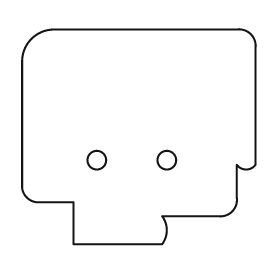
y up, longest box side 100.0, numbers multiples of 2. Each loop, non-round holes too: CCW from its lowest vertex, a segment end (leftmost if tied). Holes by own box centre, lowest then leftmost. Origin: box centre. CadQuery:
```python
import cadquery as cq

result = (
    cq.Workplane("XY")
    .moveTo(-28.0, -46.0)
    .lineTo(10.0, -46.0)
    .threePointArc((12.0, -40.0), (10.0, -34.0))
    .lineTo(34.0, -34.0)
    .threePointArc((40.0, -32.0), (42.0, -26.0))
    .lineTo(42.0, -12.0)
    .threePointArc((46.0, -14.0), (50.0, -12.0))
    .lineTo(50.0, 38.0)
    .threePointArc((48.0, 44.0), (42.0, 46.0))
    .lineTo(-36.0, 46.0)
    .threePointArc((-46.0, 42.0), (-50.0, 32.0))
    .lineTo(-50.0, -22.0)
    .threePointArc((-48.0, -26.0), (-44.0, -28.0))
    .lineTo(-28.0, -28.0)
    .close()
    .moveTo(-18.0, -10.0)
    .circle(4.0)
    .moveTo(12.0, -10.0)
    .circle(4.0)
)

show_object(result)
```